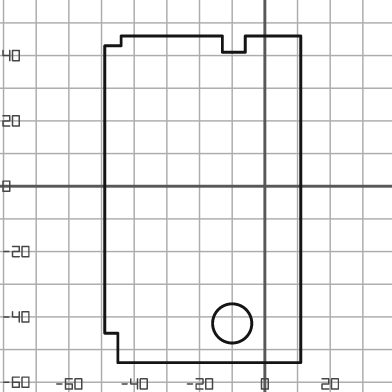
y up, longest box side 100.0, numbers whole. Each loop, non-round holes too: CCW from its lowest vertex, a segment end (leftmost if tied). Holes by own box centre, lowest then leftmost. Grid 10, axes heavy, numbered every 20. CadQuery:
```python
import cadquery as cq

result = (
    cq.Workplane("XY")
    .moveTo(-45.0, -54.0)
    .lineTo(11.0, -54.0)
    .lineTo(11.0, 46.0)
    .lineTo(-6.0, 46.0)
    .lineTo(-6.0, 41.0)
    .lineTo(-13.0, 41.0)
    .lineTo(-13.0, 46.0)
    .lineTo(-44.0, 46.0)
    .lineTo(-44.0, 43.0)
    .lineTo(-49.0, 43.0)
    .lineTo(-49.0, -45.0)
    .lineTo(-45.0, -45.0)
    .close()
    .moveTo(-10.0, -42.0)
    .circle(6.0)
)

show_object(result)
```